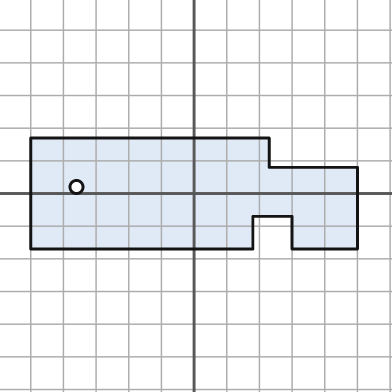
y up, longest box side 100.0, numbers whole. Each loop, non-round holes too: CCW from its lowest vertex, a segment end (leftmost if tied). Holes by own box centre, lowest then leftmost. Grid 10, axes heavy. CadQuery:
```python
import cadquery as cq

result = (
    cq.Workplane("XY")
    .moveTo(-50.0, -17.0)
    .lineTo(18.0, -17.0)
    .lineTo(18.0, -7.0)
    .lineTo(30.0, -7.0)
    .lineTo(30.0, -17.0)
    .lineTo(50.0, -17.0)
    .lineTo(50.0, 8.0)
    .lineTo(23.0, 8.0)
    .lineTo(23.0, 17.0)
    .lineTo(-50.0, 17.0)
    .close()
    .moveTo(-36.0, 2.0)
    .circle(2.0)
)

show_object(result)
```